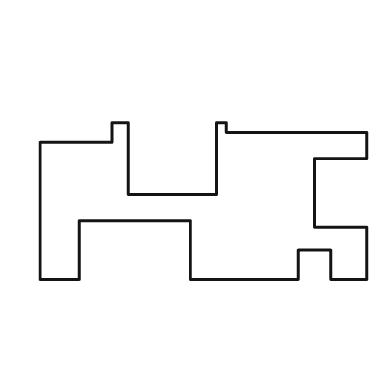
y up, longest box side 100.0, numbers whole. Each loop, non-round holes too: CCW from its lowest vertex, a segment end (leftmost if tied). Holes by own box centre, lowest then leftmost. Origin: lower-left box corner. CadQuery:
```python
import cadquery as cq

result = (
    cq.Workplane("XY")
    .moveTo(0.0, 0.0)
    .lineTo(12.0, 0.0)
    .lineTo(12.0, 18.0)
    .lineTo(46.0, 18.0)
    .lineTo(46.0, 0.0)
    .lineTo(79.0, 0.0)
    .lineTo(79.0, 9.0)
    .lineTo(89.0, 9.0)
    .lineTo(89.0, 0.0)
    .lineTo(100.0, 0.0)
    .lineTo(100.0, 16.0)
    .lineTo(84.0, 16.0)
    .lineTo(84.0, 37.0)
    .lineTo(100.0, 37.0)
    .lineTo(100.0, 45.0)
    .lineTo(57.0, 45.0)
    .lineTo(57.0, 48.0)
    .lineTo(54.0, 48.0)
    .lineTo(54.0, 26.0)
    .lineTo(27.0, 26.0)
    .lineTo(27.0, 48.0)
    .lineTo(22.0, 48.0)
    .lineTo(22.0, 42.0)
    .lineTo(0.0, 42.0)
    .close()
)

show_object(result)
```